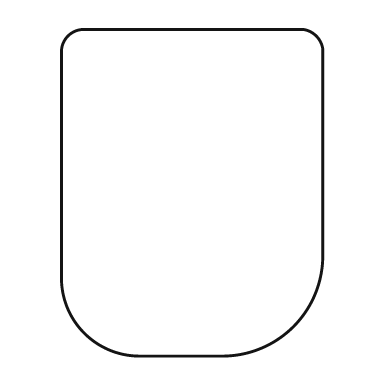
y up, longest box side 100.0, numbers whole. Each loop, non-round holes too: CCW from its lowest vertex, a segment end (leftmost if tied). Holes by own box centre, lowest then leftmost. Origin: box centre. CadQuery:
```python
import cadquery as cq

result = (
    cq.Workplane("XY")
    .moveTo(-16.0, -50.0)
    .lineTo(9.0, -50.0)
    .threePointArc((31.0, -41.0), (40.0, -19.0))
    .lineTo(40.0, 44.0)
    .threePointArc((38.0, 48.0), (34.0, 50.0))
    .lineTo(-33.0, 50.0)
    .threePointArc((-38.0, 48.0), (-40.0, 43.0))
    .lineTo(-40.0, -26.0)
    .threePointArc((-33.0, -43.0), (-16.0, -50.0))
    .close()
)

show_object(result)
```